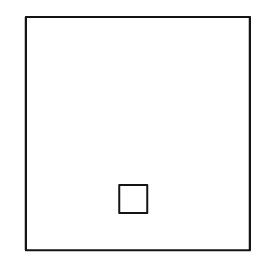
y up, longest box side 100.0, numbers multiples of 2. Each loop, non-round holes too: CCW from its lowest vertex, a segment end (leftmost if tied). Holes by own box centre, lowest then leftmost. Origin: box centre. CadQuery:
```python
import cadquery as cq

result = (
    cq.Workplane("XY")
    .moveTo(-48.0, -50.0)
    .lineTo(48.0, -50.0)
    .lineTo(48.0, 50.0)
    .lineTo(-48.0, 50.0)
    .close()
    .moveTo(-8.0, -34.0)
    .lineTo(4.0, -34.0)
    .lineTo(4.0, -22.0)
    .lineTo(-8.0, -22.0)
    .close()
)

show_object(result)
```